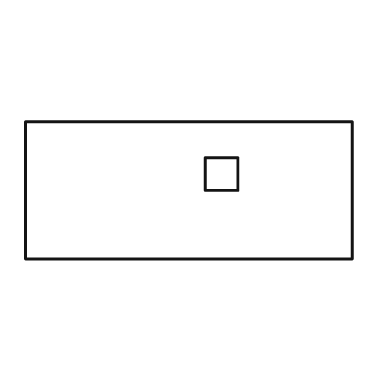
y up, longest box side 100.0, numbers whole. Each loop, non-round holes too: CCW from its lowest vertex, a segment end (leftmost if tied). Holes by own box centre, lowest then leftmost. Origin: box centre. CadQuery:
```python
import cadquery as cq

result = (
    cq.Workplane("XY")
    .moveTo(-50.0, -21.0)
    .lineTo(50.0, -21.0)
    .lineTo(50.0, 21.0)
    .lineTo(-50.0, 21.0)
    .close()
    .moveTo(5.0, 0.0)
    .lineTo(15.0, 0.0)
    .lineTo(15.0, 10.0)
    .lineTo(5.0, 10.0)
    .close()
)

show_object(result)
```